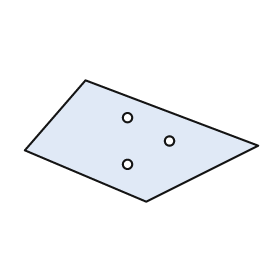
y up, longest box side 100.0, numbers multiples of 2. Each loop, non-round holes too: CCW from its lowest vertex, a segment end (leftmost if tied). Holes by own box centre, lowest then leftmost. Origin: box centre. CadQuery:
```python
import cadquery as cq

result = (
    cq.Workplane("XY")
    .moveTo(2.0, -26.0)
    .lineTo(50.0, -2.0)
    .lineTo(-24.0, 26.0)
    .lineTo(-50.0, -4.0)
    .close()
    .moveTo(-6.0, -10.0)
    .circle(2.0)
    .moveTo(12.0, 0.0)
    .circle(2.0)
    .moveTo(-6.0, 10.0)
    .circle(2.0)
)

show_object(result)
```